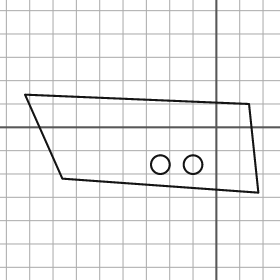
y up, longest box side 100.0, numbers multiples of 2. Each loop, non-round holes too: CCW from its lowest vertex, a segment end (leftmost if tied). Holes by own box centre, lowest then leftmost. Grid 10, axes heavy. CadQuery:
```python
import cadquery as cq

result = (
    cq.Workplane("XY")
    .moveTo(18.0, -28.0)
    .lineTo(14.0, 10.0)
    .lineTo(-82.0, 14.0)
    .lineTo(-66.0, -22.0)
    .close()
    .moveTo(-24.0, -16.0)
    .circle(4.0)
    .moveTo(-10.0, -16.0)
    .circle(4.0)
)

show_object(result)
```